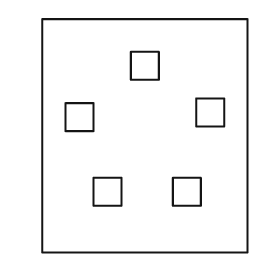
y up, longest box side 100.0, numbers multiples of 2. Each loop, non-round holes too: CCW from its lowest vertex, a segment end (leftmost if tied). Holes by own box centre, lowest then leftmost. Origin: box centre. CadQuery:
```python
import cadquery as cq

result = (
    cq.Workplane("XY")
    .moveTo(-44.0, -50.0)
    .lineTo(44.0, -50.0)
    .lineTo(44.0, 50.0)
    .lineTo(-44.0, 50.0)
    .close()
    .moveTo(-22.0, -30.0)
    .lineTo(-10.0, -30.0)
    .lineTo(-10.0, -18.0)
    .lineTo(-22.0, -18.0)
    .close()
    .moveTo(12.0, -30.0)
    .lineTo(24.0, -30.0)
    .lineTo(24.0, -18.0)
    .lineTo(12.0, -18.0)
    .close()
    .moveTo(-34.0, 2.0)
    .lineTo(-22.0, 2.0)
    .lineTo(-22.0, 14.0)
    .lineTo(-34.0, 14.0)
    .close()
    .moveTo(22.0, 4.0)
    .lineTo(34.0, 4.0)
    .lineTo(34.0, 16.0)
    .lineTo(22.0, 16.0)
    .close()
    .moveTo(-6.0, 24.0)
    .lineTo(6.0, 24.0)
    .lineTo(6.0, 36.0)
    .lineTo(-6.0, 36.0)
    .close()
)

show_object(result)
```